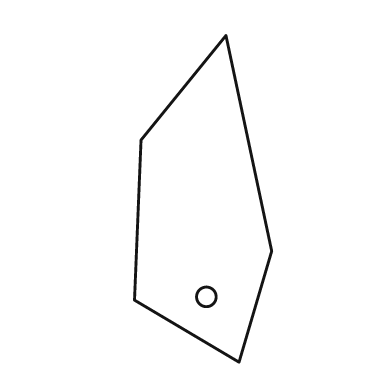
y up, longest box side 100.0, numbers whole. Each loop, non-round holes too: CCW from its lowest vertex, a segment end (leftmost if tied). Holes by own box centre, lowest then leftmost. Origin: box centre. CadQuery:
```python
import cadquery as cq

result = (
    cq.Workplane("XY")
    .moveTo(11.0, -50.0)
    .lineTo(21.0, -16.0)
    .lineTo(7.0, 50.0)
    .lineTo(-19.0, 18.0)
    .lineTo(-21.0, -31.0)
    .close()
    .moveTo(1.0, -30.0)
    .circle(3.0)
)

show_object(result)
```